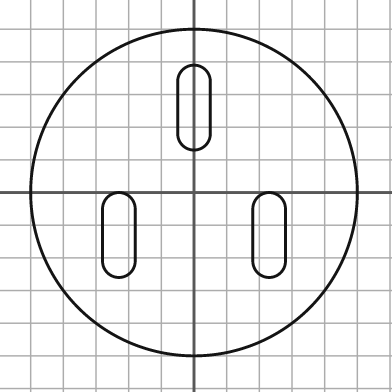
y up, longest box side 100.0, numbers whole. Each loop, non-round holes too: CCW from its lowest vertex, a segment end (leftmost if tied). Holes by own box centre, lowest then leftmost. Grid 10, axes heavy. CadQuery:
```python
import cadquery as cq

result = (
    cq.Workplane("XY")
    .moveTo(0.0, 0.0)
    .circle(50.0)
    .moveTo(-28.0, -21.0)
    .threePointArc((-23.0, -26.0), (-18.0, -21.0))
    .lineTo(-18.0, -5.0)
    .threePointArc((-23.0, 0.0), (-28.0, -5.0))
    .close()
    .moveTo(18.0, -21.0)
    .threePointArc((23.0, -26.0), (28.0, -21.0))
    .lineTo(28.0, -5.0)
    .threePointArc((23.0, 0.0), (18.0, -5.0))
    .close()
    .moveTo(-5.0, 18.0)
    .threePointArc((0.0, 13.0), (5.0, 18.0))
    .lineTo(5.0, 34.0)
    .threePointArc((0.0, 39.0), (-5.0, 34.0))
    .close()
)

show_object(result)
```